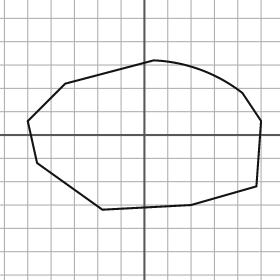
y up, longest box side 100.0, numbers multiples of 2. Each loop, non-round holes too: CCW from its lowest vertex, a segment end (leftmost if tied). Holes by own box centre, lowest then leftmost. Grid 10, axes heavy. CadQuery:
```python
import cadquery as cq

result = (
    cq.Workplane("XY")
    .moveTo(-18.0, -32.0)
    .lineTo(20.0, -30.0)
    .lineTo(48.0, -22.0)
    .lineTo(50.0, 6.0)
    .lineTo(42.0, 18.0)
    .threePointArc((24.0, 28.0), (4.0, 32.0))
    .lineTo(-34.0, 22.0)
    .lineTo(-50.0, 6.0)
    .lineTo(-46.0, -12.0)
    .close()
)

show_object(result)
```